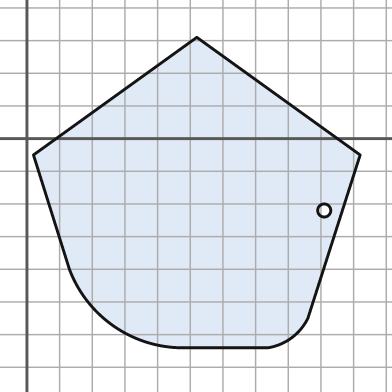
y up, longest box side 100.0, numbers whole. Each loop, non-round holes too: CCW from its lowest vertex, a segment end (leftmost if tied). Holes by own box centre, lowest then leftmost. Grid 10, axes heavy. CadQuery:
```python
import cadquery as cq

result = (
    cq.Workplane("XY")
    .moveTo(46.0, -64.0)
    .lineTo(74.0, -64.0)
    .threePointArc((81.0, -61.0), (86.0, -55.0))
    .lineTo(102.0, -5.0)
    .lineTo(52.0, 31.0)
    .lineTo(2.0, -5.0)
    .lineTo(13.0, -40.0)
    .threePointArc((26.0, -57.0), (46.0, -64.0))
    .close()
    .moveTo(91.0, -22.0)
    .circle(2.0)
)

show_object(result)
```